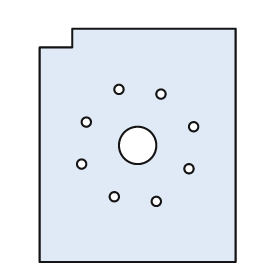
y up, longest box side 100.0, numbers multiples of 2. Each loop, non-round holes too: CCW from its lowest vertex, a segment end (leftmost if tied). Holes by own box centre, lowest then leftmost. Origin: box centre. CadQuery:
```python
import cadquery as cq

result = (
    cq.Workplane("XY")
    .moveTo(-42.0, -50.0)
    .lineTo(42.0, -50.0)
    .lineTo(42.0, 50.0)
    .lineTo(-28.0, 50.0)
    .lineTo(-28.0, 42.0)
    .lineTo(-42.0, 42.0)
    .close()
    .moveTo(8.0, -24.0)
    .circle(2.0)
    .moveTo(-10.0, -22.0)
    .circle(2.0)
    .moveTo(22.0, -10.0)
    .circle(2.0)
    .moveTo(-24.0, -8.0)
    .circle(2.0)
    .moveTo(0.0, 0.0)
    .circle(8.0)
    .moveTo(24.0, 8.0)
    .circle(2.0)
    .moveTo(-22.0, 10.0)
    .circle(2.0)
    .moveTo(10.0, 22.0)
    .circle(2.0)
    .moveTo(-8.0, 24.0)
    .circle(2.0)
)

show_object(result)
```